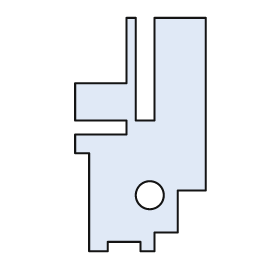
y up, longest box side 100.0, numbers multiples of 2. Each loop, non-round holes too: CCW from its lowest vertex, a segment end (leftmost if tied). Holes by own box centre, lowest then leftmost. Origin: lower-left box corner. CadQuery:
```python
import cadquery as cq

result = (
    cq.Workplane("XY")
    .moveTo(6.0, 0.0)
    .lineTo(14.0, 0.0)
    .lineTo(14.0, 4.0)
    .lineTo(28.0, 4.0)
    .lineTo(28.0, 0.0)
    .lineTo(34.0, 0.0)
    .lineTo(34.0, 8.0)
    .lineTo(44.0, 8.0)
    .lineTo(44.0, 26.0)
    .lineTo(56.0, 26.0)
    .lineTo(56.0, 100.0)
    .lineTo(34.0, 100.0)
    .lineTo(34.0, 56.0)
    .lineTo(26.0, 56.0)
    .lineTo(26.0, 100.0)
    .lineTo(22.0, 100.0)
    .lineTo(22.0, 72.0)
    .lineTo(0.0, 72.0)
    .lineTo(0.0, 56.0)
    .lineTo(22.0, 56.0)
    .lineTo(22.0, 50.0)
    .lineTo(0.0, 50.0)
    .lineTo(0.0, 42.0)
    .lineTo(6.0, 42.0)
    .close()
    .moveTo(32.0, 24.0)
    .circle(6.0)
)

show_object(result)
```